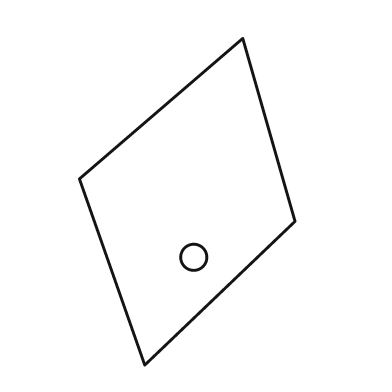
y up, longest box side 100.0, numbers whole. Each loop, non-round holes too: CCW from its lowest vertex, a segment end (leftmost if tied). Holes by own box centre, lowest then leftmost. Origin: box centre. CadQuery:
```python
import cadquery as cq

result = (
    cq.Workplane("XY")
    .moveTo(-13.0, -50.0)
    .lineTo(33.0, -6.0)
    .lineTo(17.0, 50.0)
    .lineTo(-33.0, 7.0)
    .close()
    .moveTo(2.0, -17.0)
    .circle(4.0)
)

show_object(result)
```